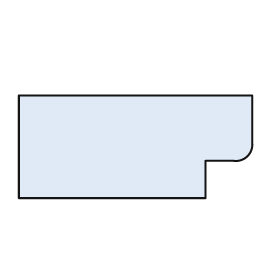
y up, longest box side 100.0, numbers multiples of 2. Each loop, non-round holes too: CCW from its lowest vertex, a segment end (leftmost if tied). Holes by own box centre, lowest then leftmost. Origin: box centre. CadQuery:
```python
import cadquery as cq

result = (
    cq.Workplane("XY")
    .moveTo(-50.0, -22.0)
    .lineTo(30.0, -22.0)
    .lineTo(30.0, -6.0)
    .lineTo(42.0, -6.0)
    .threePointArc((48.0, -4.0), (50.0, 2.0))
    .lineTo(50.0, 22.0)
    .lineTo(-50.0, 22.0)
    .close()
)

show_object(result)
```